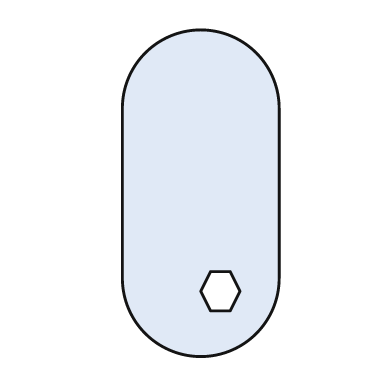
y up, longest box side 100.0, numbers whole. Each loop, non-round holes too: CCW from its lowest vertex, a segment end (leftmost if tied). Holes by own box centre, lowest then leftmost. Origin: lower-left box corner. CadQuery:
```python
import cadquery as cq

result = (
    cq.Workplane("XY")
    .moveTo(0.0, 24.0)
    .threePointArc((24.0, 0.0), (48.0, 24.0))
    .lineTo(48.0, 76.0)
    .threePointArc((24.0, 100.0), (0.0, 76.0))
    .close()
    .moveTo(27.0, 14.0)
    .lineTo(33.0, 14.0)
    .lineTo(36.0, 20.0)
    .lineTo(33.0, 26.0)
    .lineTo(27.0, 26.0)
    .lineTo(24.0, 20.0)
    .close()
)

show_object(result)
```